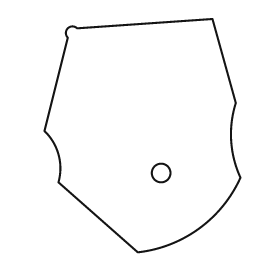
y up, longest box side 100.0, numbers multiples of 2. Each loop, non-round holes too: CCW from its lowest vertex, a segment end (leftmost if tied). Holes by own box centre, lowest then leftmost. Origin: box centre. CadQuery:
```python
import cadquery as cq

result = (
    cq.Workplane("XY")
    .moveTo(-2.0, -50.0)
    .threePointArc((24.0, -40.0), (42.0, -18.0))
    .threePointArc((38.0, -2.0), (40.0, 14.0))
    .lineTo(30.0, 50.0)
    .lineTo(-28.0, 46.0)
    .threePointArc((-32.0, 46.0), (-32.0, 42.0))
    .lineTo(-42.0, 2.0)
    .threePointArc((-36.0, -8.0), (-36.0, -20.0))
    .close()
    .moveTo(8.0, -16.0)
    .circle(4.0)
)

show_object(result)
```